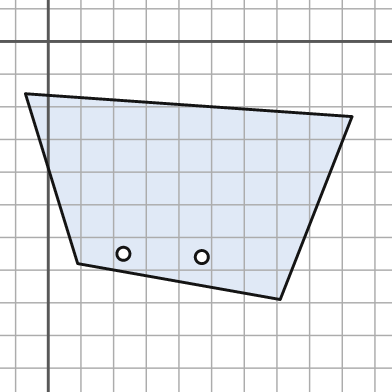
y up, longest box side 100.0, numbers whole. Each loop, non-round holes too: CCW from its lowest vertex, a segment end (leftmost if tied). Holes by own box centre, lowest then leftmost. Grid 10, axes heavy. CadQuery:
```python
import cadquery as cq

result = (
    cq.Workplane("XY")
    .moveTo(71.0, -79.0)
    .lineTo(93.0, -23.0)
    .lineTo(-7.0, -16.0)
    .lineTo(9.0, -68.0)
    .close()
    .moveTo(47.0, -66.0)
    .circle(2.0)
    .moveTo(23.0, -65.0)
    .circle(2.0)
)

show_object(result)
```